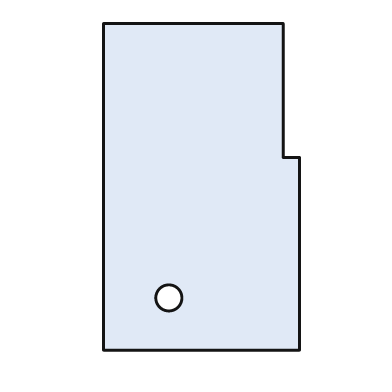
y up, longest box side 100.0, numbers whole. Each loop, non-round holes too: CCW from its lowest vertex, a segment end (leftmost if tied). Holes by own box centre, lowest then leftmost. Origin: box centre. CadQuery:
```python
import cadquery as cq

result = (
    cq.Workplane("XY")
    .moveTo(-30.0, -50.0)
    .lineTo(30.0, -50.0)
    .lineTo(30.0, 9.0)
    .lineTo(25.0, 9.0)
    .lineTo(25.0, 50.0)
    .lineTo(-30.0, 50.0)
    .close()
    .moveTo(-10.0, -34.0)
    .circle(4.0)
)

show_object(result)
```